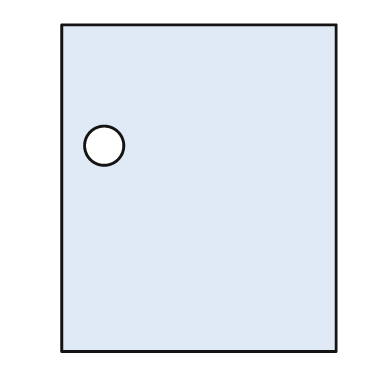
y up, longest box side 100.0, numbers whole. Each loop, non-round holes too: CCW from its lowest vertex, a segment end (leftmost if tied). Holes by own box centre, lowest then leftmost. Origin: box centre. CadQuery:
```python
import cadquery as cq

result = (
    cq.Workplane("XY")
    .moveTo(-42.0, -50.0)
    .lineTo(42.0, -50.0)
    .lineTo(42.0, 50.0)
    .lineTo(-42.0, 50.0)
    .close()
    .moveTo(-29.0, 13.0)
    .circle(6.0)
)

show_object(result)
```